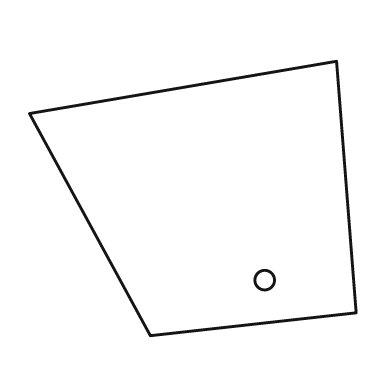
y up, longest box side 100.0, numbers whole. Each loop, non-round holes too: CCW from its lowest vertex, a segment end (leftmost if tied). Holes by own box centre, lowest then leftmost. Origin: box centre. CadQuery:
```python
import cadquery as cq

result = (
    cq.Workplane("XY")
    .moveTo(-13.0, -42.0)
    .lineTo(50.0, -35.0)
    .lineTo(44.0, 42.0)
    .lineTo(-50.0, 26.0)
    .close()
    .moveTo(22.0, -25.0)
    .circle(3.0)
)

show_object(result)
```